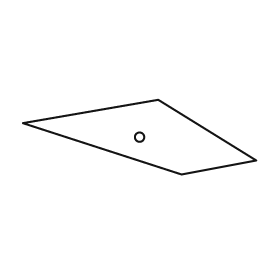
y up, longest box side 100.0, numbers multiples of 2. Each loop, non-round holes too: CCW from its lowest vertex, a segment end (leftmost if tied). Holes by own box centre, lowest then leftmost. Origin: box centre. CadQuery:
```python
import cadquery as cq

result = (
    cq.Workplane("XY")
    .moveTo(18.0, -16.0)
    .lineTo(50.0, -10.0)
    .lineTo(8.0, 16.0)
    .lineTo(-50.0, 6.0)
    .close()
    .moveTo(0.0, 0.0)
    .circle(2.0)
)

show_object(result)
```